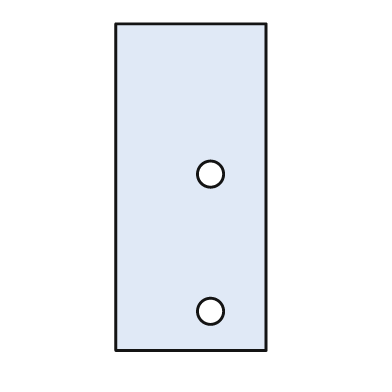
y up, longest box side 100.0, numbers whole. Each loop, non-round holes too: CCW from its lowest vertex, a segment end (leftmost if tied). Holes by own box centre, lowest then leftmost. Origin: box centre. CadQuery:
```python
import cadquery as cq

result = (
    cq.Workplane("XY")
    .moveTo(-23.0, -50.0)
    .lineTo(23.0, -50.0)
    .lineTo(23.0, 50.0)
    .lineTo(-23.0, 50.0)
    .close()
    .moveTo(6.0, -38.0)
    .circle(4.0)
    .moveTo(6.0, 4.0)
    .circle(4.0)
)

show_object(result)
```